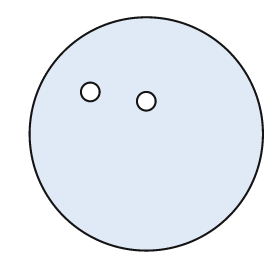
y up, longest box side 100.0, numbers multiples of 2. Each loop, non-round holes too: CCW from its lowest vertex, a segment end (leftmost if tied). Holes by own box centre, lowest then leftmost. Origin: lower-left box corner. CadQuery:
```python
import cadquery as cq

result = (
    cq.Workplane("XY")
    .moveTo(50.0, 50.0)
    .circle(50.0)
    .moveTo(50.0, 64.0)
    .circle(4.0)
    .moveTo(26.0, 68.0)
    .circle(4.0)
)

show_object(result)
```